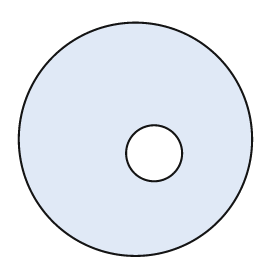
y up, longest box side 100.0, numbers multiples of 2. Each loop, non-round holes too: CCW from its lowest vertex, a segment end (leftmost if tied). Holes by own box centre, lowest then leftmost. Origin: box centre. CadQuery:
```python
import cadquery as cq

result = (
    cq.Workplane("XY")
    .moveTo(0.0, 0.0)
    .circle(50.0)
    .moveTo(8.0, -6.0)
    .circle(12.0)
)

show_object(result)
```